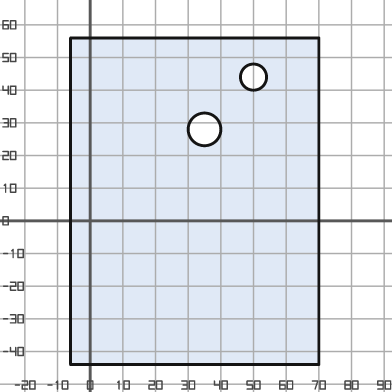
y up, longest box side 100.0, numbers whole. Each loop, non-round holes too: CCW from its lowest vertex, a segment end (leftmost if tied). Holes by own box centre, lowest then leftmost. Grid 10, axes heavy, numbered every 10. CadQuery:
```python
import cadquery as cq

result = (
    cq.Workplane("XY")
    .moveTo(-6.0, -44.0)
    .lineTo(70.0, -44.0)
    .lineTo(70.0, 56.0)
    .lineTo(-6.0, 56.0)
    .close()
    .moveTo(35.0, 28.0)
    .circle(5.0)
    .moveTo(50.0, 44.0)
    .circle(4.0)
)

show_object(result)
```